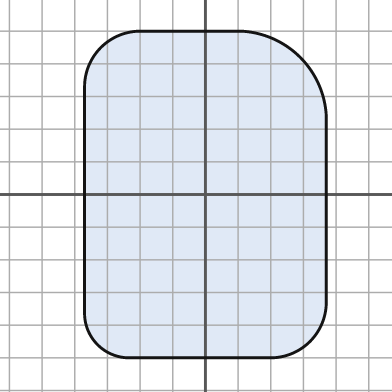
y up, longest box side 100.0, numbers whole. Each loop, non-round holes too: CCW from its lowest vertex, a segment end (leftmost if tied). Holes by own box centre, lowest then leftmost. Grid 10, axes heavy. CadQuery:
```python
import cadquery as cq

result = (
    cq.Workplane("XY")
    .moveTo(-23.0, -50.0)
    .lineTo(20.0, -50.0)
    .threePointArc((32.0, -45.0), (37.0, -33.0))
    .lineTo(37.0, 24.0)
    .threePointArc((29.0, 42.0), (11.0, 50.0))
    .lineTo(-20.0, 50.0)
    .threePointArc((-32.0, 45.0), (-37.0, 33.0))
    .lineTo(-37.0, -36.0)
    .threePointArc((-33.0, -46.0), (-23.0, -50.0))
    .close()
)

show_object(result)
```